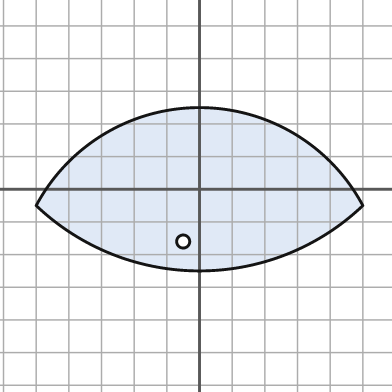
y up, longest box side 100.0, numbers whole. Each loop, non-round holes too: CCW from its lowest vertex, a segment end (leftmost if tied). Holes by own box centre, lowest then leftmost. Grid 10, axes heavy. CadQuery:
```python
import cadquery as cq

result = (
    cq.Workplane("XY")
    .moveTo(-50.0, -5.0)
    .threePointArc((0.0, -25.0), (50.0, -5.0))
    .threePointArc((0.0, 25.0), (-50.0, -5.0))
    .close()
    .moveTo(-5.0, -16.0)
    .circle(2.0)
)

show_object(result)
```